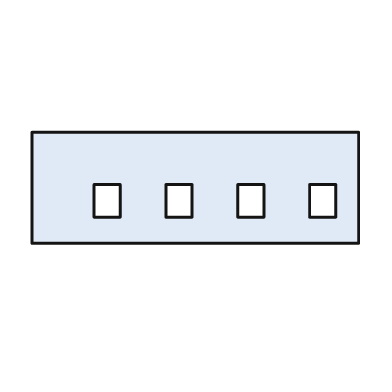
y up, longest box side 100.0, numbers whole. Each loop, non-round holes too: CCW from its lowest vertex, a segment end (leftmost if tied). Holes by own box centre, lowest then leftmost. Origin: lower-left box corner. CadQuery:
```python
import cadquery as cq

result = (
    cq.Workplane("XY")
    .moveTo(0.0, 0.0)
    .lineTo(100.0, 0.0)
    .lineTo(100.0, 34.0)
    .lineTo(0.0, 34.0)
    .close()
    .moveTo(19.0, 8.0)
    .lineTo(27.0, 8.0)
    .lineTo(27.0, 18.0)
    .lineTo(19.0, 18.0)
    .close()
    .moveTo(41.0, 8.0)
    .lineTo(49.0, 8.0)
    .lineTo(49.0, 18.0)
    .lineTo(41.0, 18.0)
    .close()
    .moveTo(63.0, 8.0)
    .lineTo(71.0, 8.0)
    .lineTo(71.0, 18.0)
    .lineTo(63.0, 18.0)
    .close()
    .moveTo(85.0, 8.0)
    .lineTo(93.0, 8.0)
    .lineTo(93.0, 18.0)
    .lineTo(85.0, 18.0)
    .close()
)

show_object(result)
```